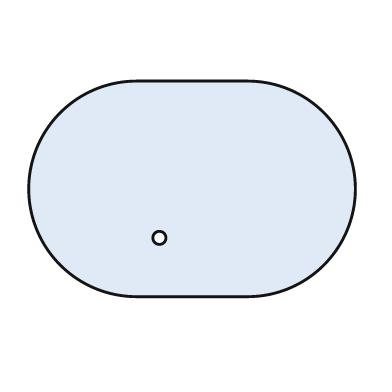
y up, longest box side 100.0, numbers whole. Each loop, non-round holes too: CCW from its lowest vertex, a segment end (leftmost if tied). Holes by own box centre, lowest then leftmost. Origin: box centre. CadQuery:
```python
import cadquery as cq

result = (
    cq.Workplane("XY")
    .moveTo(-17.0, -33.0)
    .lineTo(17.0, -33.0)
    .threePointArc((50.0, 0.0), (17.0, 33.0))
    .lineTo(-17.0, 33.0)
    .threePointArc((-50.0, 0.0), (-17.0, -33.0))
    .close()
    .moveTo(-10.0, -15.0)
    .circle(2.0)
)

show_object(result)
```